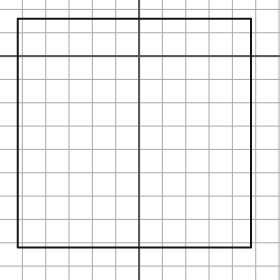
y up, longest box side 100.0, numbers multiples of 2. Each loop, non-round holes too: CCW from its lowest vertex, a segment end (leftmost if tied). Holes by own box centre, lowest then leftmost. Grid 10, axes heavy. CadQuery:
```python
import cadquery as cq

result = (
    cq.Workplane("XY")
    .moveTo(-52.0, -82.0)
    .lineTo(48.0, -82.0)
    .lineTo(48.0, 16.0)
    .lineTo(-52.0, 16.0)
    .close()
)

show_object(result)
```